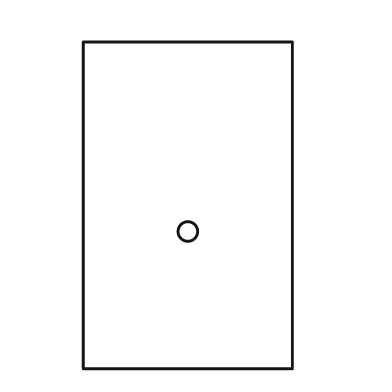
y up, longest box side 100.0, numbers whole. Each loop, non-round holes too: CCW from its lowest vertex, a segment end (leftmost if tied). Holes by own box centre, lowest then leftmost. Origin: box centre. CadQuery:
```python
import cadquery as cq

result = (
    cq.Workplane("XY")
    .moveTo(-32.0, -50.0)
    .lineTo(32.0, -50.0)
    .lineTo(32.0, 50.0)
    .lineTo(-32.0, 50.0)
    .close()
    .moveTo(0.0, -8.0)
    .circle(3.0)
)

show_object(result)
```